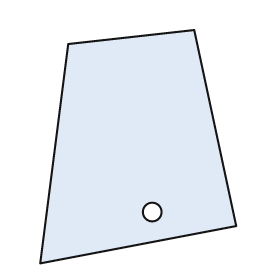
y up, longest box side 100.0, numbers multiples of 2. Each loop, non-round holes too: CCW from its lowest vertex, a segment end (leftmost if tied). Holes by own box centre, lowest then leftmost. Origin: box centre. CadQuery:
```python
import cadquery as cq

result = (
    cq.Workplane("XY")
    .moveTo(-42.0, -50.0)
    .lineTo(42.0, -34.0)
    .lineTo(24.0, 50.0)
    .lineTo(-30.0, 44.0)
    .close()
    .moveTo(6.0, -28.0)
    .circle(4.0)
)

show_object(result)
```